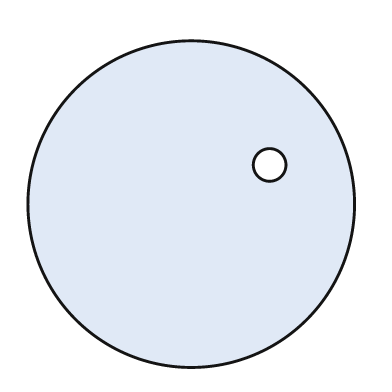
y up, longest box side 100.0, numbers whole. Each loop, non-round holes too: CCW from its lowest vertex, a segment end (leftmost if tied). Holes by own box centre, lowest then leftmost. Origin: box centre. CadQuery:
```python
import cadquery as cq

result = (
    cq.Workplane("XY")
    .moveTo(0.0, 0.0)
    .circle(50.0)
    .moveTo(24.0, 12.0)
    .circle(5.0)
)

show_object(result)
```